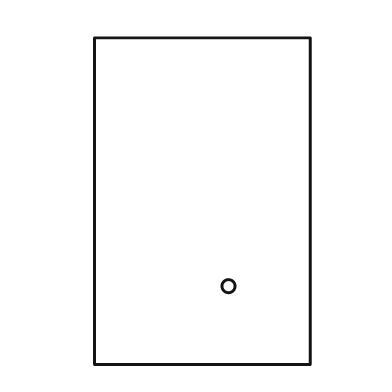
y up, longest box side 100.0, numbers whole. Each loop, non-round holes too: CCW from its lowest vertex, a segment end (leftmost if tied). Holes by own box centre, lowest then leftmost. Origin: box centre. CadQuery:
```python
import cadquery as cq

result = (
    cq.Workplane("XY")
    .moveTo(-33.0, -50.0)
    .lineTo(33.0, -50.0)
    .lineTo(33.0, 50.0)
    .lineTo(-33.0, 50.0)
    .close()
    .moveTo(8.0, -26.0)
    .circle(2.0)
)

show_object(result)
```